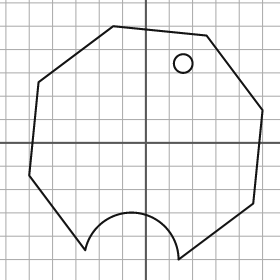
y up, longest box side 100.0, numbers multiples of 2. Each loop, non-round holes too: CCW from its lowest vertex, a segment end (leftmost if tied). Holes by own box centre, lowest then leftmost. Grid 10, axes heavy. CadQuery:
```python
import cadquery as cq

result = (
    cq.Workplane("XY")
    .moveTo(14.0, -50.0)
    .lineTo(46.0, -26.0)
    .lineTo(50.0, 14.0)
    .lineTo(26.0, 46.0)
    .lineTo(-14.0, 50.0)
    .lineTo(-46.0, 26.0)
    .lineTo(-50.0, -14.0)
    .lineTo(-26.0, -46.0)
    .threePointArc((-4.0, -30.0), (14.0, -50.0))
    .close()
    .moveTo(16.0, 34.0)
    .circle(4.0)
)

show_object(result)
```